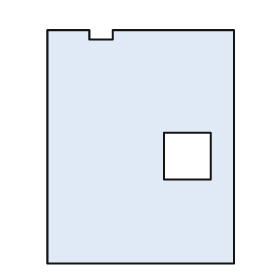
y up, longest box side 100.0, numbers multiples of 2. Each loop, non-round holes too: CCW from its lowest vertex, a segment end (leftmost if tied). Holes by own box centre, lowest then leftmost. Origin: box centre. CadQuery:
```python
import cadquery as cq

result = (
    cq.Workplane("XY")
    .moveTo(-40.0, -50.0)
    .lineTo(40.0, -50.0)
    .lineTo(40.0, 50.0)
    .lineTo(-12.0, 50.0)
    .lineTo(-12.0, 46.0)
    .lineTo(-22.0, 46.0)
    .lineTo(-22.0, 50.0)
    .lineTo(-40.0, 50.0)
    .close()
    .moveTo(10.0, -14.0)
    .lineTo(30.0, -14.0)
    .lineTo(30.0, 6.0)
    .lineTo(10.0, 6.0)
    .close()
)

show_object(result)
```